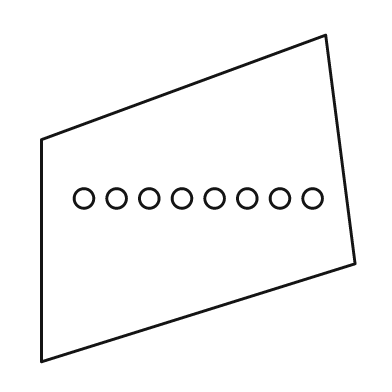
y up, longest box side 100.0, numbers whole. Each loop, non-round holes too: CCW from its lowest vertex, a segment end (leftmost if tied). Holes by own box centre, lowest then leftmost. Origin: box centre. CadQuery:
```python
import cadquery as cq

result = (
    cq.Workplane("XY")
    .moveTo(-48.0, -50.0)
    .lineTo(48.0, -20.0)
    .lineTo(39.0, 50.0)
    .lineTo(-48.0, 18.0)
    .close()
    .moveTo(-35.0, 0.0)
    .circle(3.0)
    .moveTo(-25.0, 0.0)
    .circle(3.0)
    .moveTo(-15.0, 0.0)
    .circle(3.0)
    .moveTo(-5.0, 0.0)
    .circle(3.0)
    .moveTo(5.0, 0.0)
    .circle(3.0)
    .moveTo(15.0, 0.0)
    .circle(3.0)
    .moveTo(25.0, 0.0)
    .circle(3.0)
    .moveTo(35.0, 0.0)
    .circle(3.0)
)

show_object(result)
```